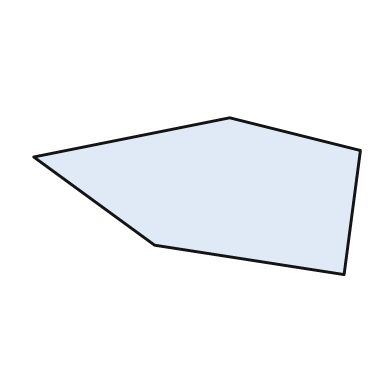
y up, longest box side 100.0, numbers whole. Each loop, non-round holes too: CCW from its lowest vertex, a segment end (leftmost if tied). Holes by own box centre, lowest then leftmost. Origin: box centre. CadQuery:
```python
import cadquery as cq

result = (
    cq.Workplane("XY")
    .moveTo(45.0, -24.0)
    .lineTo(50.0, 14.0)
    .lineTo(10.0, 24.0)
    .lineTo(-50.0, 12.0)
    .lineTo(-13.0, -15.0)
    .close()
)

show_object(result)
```